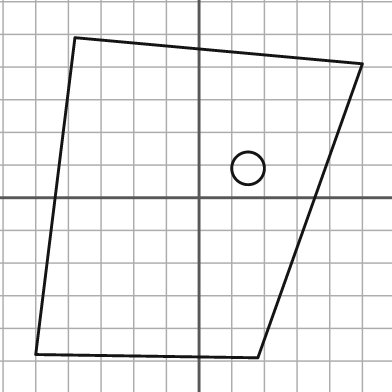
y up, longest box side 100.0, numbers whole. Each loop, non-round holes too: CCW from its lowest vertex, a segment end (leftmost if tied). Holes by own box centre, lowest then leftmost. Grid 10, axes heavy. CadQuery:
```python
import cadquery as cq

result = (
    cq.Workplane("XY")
    .moveTo(18.0, -49.0)
    .lineTo(50.0, 41.0)
    .lineTo(-38.0, 49.0)
    .lineTo(-50.0, -48.0)
    .close()
    .moveTo(15.0, 9.0)
    .circle(5.0)
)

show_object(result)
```